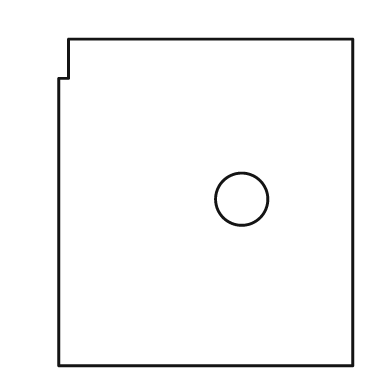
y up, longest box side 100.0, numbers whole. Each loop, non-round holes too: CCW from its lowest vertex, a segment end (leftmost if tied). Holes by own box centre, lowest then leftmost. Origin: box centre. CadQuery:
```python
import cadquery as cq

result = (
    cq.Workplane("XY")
    .moveTo(-45.0, -50.0)
    .lineTo(45.0, -50.0)
    .lineTo(45.0, 50.0)
    .lineTo(-42.0, 50.0)
    .lineTo(-42.0, 38.0)
    .lineTo(-45.0, 38.0)
    .close()
    .moveTo(11.0, 1.0)
    .circle(8.0)
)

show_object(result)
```